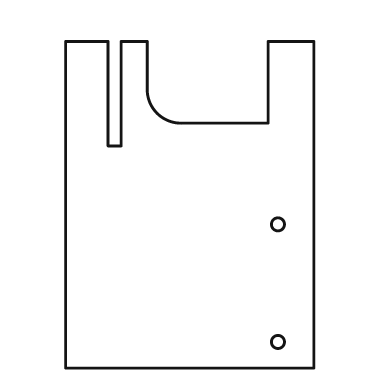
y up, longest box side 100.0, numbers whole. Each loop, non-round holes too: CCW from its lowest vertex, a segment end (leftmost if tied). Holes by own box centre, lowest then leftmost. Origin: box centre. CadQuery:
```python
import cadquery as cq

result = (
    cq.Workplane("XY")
    .moveTo(-38.0, -50.0)
    .lineTo(38.0, -50.0)
    .lineTo(38.0, 50.0)
    .lineTo(24.0, 50.0)
    .lineTo(24.0, 25.0)
    .lineTo(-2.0, 25.0)
    .threePointArc((-10.0, 28.0), (-13.0, 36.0))
    .lineTo(-13.0, 50.0)
    .lineTo(-21.0, 50.0)
    .lineTo(-21.0, 18.0)
    .lineTo(-25.0, 18.0)
    .lineTo(-25.0, 50.0)
    .lineTo(-38.0, 50.0)
    .close()
    .moveTo(27.0, -42.0)
    .circle(2.0)
    .moveTo(27.0, -6.0)
    .circle(2.0)
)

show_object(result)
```